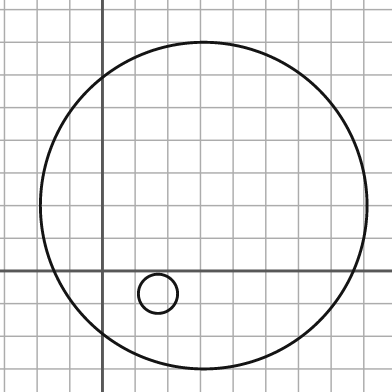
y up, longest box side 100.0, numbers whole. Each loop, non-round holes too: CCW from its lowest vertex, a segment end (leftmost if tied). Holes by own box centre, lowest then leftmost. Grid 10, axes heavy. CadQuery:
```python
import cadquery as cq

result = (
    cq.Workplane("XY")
    .moveTo(31.0, 20.0)
    .circle(50.0)
    .moveTo(17.0, -7.0)
    .circle(6.0)
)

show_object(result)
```